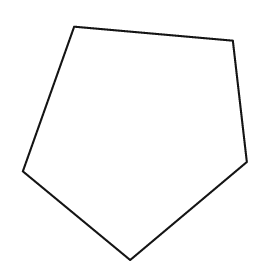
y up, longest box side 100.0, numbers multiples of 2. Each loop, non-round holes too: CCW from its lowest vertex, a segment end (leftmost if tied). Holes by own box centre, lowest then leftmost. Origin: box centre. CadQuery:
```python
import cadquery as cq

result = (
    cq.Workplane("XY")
    .moveTo(-2.0, -50.0)
    .lineTo(48.0, -8.0)
    .lineTo(42.0, 44.0)
    .lineTo(-26.0, 50.0)
    .lineTo(-48.0, -12.0)
    .close()
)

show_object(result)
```